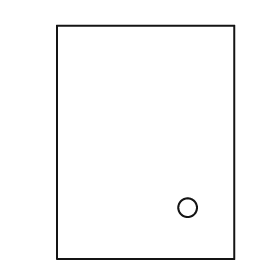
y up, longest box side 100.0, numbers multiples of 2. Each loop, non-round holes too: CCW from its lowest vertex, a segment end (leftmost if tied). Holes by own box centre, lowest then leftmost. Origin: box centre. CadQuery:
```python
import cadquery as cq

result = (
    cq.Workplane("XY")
    .moveTo(-38.0, -50.0)
    .lineTo(38.0, -50.0)
    .lineTo(38.0, 50.0)
    .lineTo(-38.0, 50.0)
    .close()
    .moveTo(18.0, -28.0)
    .circle(4.0)
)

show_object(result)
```